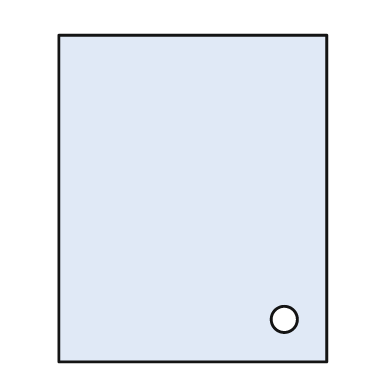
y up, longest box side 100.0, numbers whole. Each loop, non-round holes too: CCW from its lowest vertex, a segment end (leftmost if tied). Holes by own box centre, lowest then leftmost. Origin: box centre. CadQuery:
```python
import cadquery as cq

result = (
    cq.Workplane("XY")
    .moveTo(-41.0, -50.0)
    .lineTo(41.0, -50.0)
    .lineTo(41.0, 50.0)
    .lineTo(-41.0, 50.0)
    .close()
    .moveTo(28.0, -37.0)
    .circle(4.0)
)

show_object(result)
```